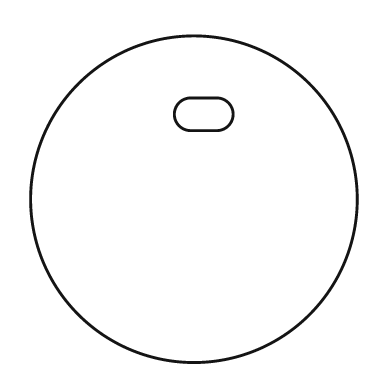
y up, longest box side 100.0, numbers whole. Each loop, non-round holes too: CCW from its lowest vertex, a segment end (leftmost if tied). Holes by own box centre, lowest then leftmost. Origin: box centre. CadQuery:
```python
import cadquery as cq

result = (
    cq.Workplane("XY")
    .moveTo(0.0, 0.0)
    .circle(50.0)
    .moveTo(-1.0, 21.0)
    .lineTo(7.0, 21.0)
    .threePointArc((12.0, 26.0), (7.0, 31.0))
    .lineTo(-1.0, 31.0)
    .threePointArc((-6.0, 26.0), (-1.0, 21.0))
    .close()
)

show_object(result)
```